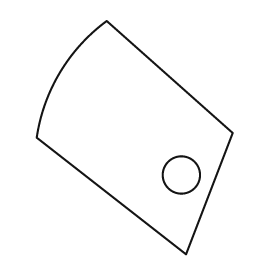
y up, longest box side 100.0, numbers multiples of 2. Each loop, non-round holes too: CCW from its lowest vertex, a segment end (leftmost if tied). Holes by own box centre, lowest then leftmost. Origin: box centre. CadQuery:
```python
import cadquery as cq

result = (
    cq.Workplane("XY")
    .moveTo(22.0, -50.0)
    .lineTo(42.0, 2.0)
    .lineTo(-12.0, 50.0)
    .threePointArc((-32.0, 28.0), (-42.0, 0.0))
    .close()
    .moveTo(20.0, -16.0)
    .circle(8.0)
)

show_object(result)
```